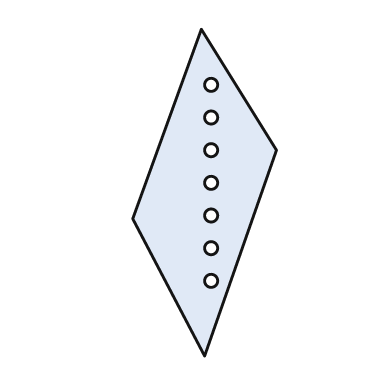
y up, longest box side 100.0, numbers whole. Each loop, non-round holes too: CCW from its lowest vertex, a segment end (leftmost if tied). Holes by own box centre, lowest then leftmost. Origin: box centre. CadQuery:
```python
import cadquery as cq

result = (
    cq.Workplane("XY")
    .moveTo(0.0, -50.0)
    .lineTo(22.0, 13.0)
    .lineTo(-1.0, 50.0)
    .lineTo(-22.0, -8.0)
    .close()
    .moveTo(2.0, -27.0)
    .circle(2.0)
    .moveTo(2.0, -17.0)
    .circle(2.0)
    .moveTo(2.0, -7.0)
    .circle(2.0)
    .moveTo(2.0, 3.0)
    .circle(2.0)
    .moveTo(2.0, 13.0)
    .circle(2.0)
    .moveTo(2.0, 23.0)
    .circle(2.0)
    .moveTo(2.0, 33.0)
    .circle(2.0)
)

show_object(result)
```